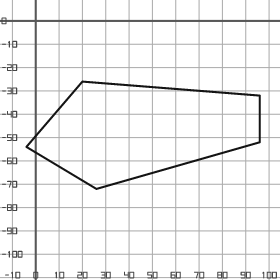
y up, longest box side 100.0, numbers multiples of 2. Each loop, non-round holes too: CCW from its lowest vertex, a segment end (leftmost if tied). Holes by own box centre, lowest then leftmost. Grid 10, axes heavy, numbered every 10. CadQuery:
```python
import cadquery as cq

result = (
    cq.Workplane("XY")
    .moveTo(26.0, -72.0)
    .lineTo(96.0, -52.0)
    .lineTo(96.0, -32.0)
    .lineTo(20.0, -26.0)
    .lineTo(-4.0, -54.0)
    .close()
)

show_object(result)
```